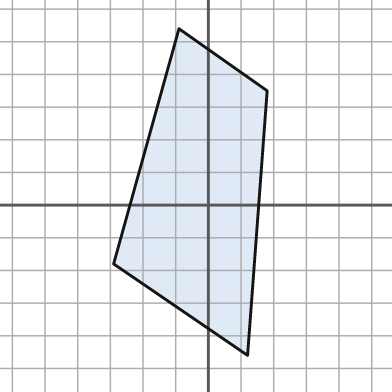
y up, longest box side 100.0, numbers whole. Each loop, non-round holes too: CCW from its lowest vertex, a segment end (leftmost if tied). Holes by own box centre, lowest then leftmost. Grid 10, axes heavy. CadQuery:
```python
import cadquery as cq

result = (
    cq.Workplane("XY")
    .moveTo(12.0, -46.0)
    .lineTo(18.0, 35.0)
    .lineTo(-9.0, 54.0)
    .lineTo(-29.0, -18.0)
    .close()
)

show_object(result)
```